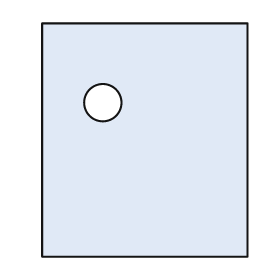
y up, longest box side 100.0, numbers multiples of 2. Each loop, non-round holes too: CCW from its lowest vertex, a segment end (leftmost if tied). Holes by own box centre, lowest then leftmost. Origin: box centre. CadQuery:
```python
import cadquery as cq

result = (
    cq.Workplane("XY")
    .moveTo(-44.0, -50.0)
    .lineTo(44.0, -50.0)
    .lineTo(44.0, 50.0)
    .lineTo(-44.0, 50.0)
    .close()
    .moveTo(-18.0, 16.0)
    .circle(8.0)
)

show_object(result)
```